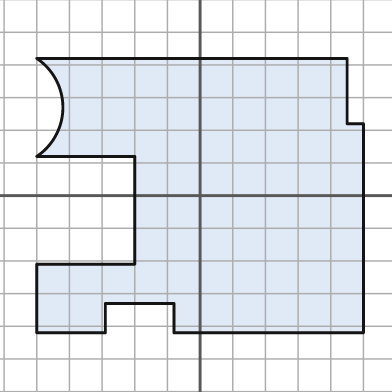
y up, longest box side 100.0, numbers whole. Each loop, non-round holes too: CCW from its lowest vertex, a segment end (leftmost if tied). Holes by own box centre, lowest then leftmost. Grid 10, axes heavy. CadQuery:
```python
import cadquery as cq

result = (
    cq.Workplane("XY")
    .moveTo(-50.0, -42.0)
    .lineTo(-29.0, -42.0)
    .lineTo(-29.0, -33.0)
    .lineTo(-8.0, -33.0)
    .lineTo(-8.0, -42.0)
    .lineTo(50.0, -42.0)
    .lineTo(50.0, 22.0)
    .lineTo(45.0, 22.0)
    .lineTo(45.0, 42.0)
    .lineTo(-50.0, 42.0)
    .threePointArc((-42.0, 27.0), (-50.0, 12.0))
    .lineTo(-20.0, 12.0)
    .lineTo(-20.0, -21.0)
    .lineTo(-50.0, -21.0)
    .close()
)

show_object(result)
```